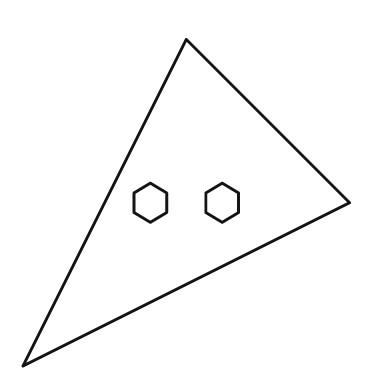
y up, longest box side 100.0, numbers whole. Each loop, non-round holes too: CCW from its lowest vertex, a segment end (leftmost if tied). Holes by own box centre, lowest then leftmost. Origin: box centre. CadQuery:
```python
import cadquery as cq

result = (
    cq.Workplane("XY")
    .moveTo(-50.0, -50.0)
    .lineTo(50.0, 0.0)
    .lineTo(0.0, 50.0)
    .close()
    .moveTo(-11.0, -6.0)
    .lineTo(-6.0, -3.0)
    .lineTo(-6.0, 3.0)
    .lineTo(-11.0, 6.0)
    .lineTo(-16.0, 3.0)
    .lineTo(-16.0, -3.0)
    .close()
    .moveTo(11.0, -6.0)
    .lineTo(16.0, -3.0)
    .lineTo(16.0, 3.0)
    .lineTo(11.0, 6.0)
    .lineTo(6.0, 3.0)
    .lineTo(6.0, -3.0)
    .close()
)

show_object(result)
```